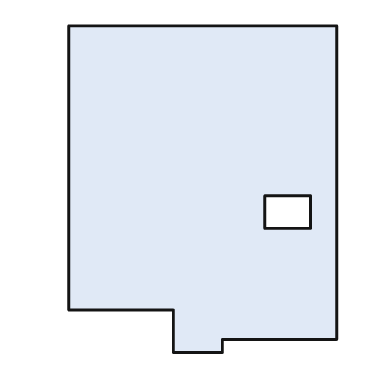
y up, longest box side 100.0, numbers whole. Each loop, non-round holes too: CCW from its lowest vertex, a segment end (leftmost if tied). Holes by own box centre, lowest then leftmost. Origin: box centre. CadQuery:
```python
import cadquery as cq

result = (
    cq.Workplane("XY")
    .moveTo(-9.0, -50.0)
    .lineTo(6.0, -50.0)
    .lineTo(6.0, -46.0)
    .lineTo(41.0, -46.0)
    .lineTo(41.0, 50.0)
    .lineTo(-41.0, 50.0)
    .lineTo(-41.0, -37.0)
    .lineTo(-9.0, -37.0)
    .close()
    .moveTo(19.0, -12.0)
    .lineTo(33.0, -12.0)
    .lineTo(33.0, -2.0)
    .lineTo(19.0, -2.0)
    .close()
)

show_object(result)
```